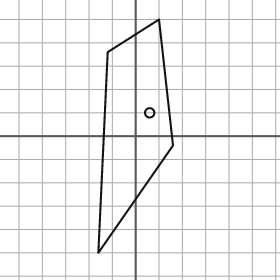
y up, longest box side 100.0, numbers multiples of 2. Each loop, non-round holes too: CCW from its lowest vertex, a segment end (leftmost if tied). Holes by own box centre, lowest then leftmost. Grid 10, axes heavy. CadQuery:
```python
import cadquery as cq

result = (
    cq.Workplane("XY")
    .moveTo(-16.0, -50.0)
    .lineTo(16.0, -4.0)
    .lineTo(10.0, 50.0)
    .lineTo(-12.0, 36.0)
    .close()
    .moveTo(6.0, 10.0)
    .circle(2.0)
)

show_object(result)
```